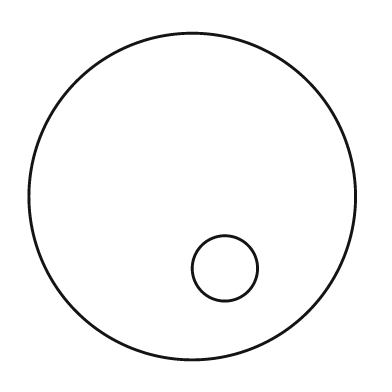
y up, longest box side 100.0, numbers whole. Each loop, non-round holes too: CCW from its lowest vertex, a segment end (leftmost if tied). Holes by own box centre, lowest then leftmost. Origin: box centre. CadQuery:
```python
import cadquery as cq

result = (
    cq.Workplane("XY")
    .moveTo(0.0, 0.0)
    .circle(50.0)
    .moveTo(10.0, -22.0)
    .circle(10.0)
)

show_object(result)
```